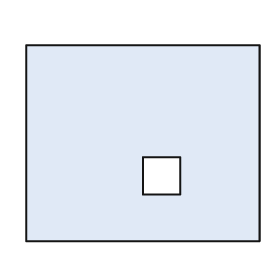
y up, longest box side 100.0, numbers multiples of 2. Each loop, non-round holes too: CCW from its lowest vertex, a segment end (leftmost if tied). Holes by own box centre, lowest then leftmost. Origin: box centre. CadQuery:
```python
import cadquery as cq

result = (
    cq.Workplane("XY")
    .moveTo(-50.0, -42.0)
    .lineTo(50.0, -42.0)
    .lineTo(50.0, 42.0)
    .lineTo(-50.0, 42.0)
    .close()
    .moveTo(0.0, -22.0)
    .lineTo(16.0, -22.0)
    .lineTo(16.0, -6.0)
    .lineTo(0.0, -6.0)
    .close()
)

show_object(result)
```